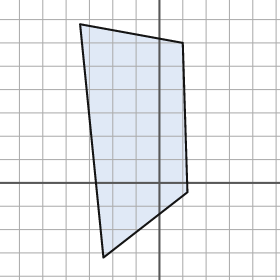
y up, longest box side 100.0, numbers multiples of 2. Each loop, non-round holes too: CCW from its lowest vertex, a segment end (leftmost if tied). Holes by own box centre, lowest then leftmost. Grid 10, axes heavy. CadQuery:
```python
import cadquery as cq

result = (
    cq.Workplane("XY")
    .moveTo(-24.0, -32.0)
    .lineTo(12.0, -4.0)
    .lineTo(10.0, 60.0)
    .lineTo(-34.0, 68.0)
    .close()
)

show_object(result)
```